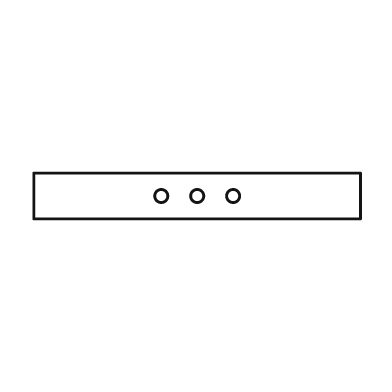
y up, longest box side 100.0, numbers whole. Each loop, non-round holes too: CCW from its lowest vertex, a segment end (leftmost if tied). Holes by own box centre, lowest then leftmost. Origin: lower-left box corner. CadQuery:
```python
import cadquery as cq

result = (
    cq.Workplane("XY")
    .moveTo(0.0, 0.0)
    .lineTo(100.0, 0.0)
    .lineTo(100.0, 14.0)
    .lineTo(0.0, 14.0)
    .close()
    .moveTo(39.0, 7.0)
    .circle(2.0)
    .moveTo(50.0, 7.0)
    .circle(2.0)
    .moveTo(61.0, 7.0)
    .circle(2.0)
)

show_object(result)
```